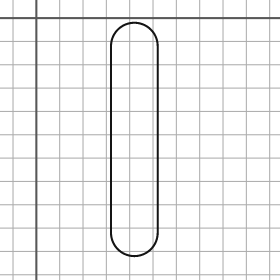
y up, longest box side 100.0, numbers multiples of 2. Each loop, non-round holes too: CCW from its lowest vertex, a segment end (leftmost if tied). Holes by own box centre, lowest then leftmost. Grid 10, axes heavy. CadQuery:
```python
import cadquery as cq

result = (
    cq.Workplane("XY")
    .moveTo(32.0, -92.0)
    .threePointArc((42.0, -102.0), (52.0, -92.0))
    .lineTo(52.0, -12.0)
    .threePointArc((42.0, -2.0), (32.0, -12.0))
    .close()
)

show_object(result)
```